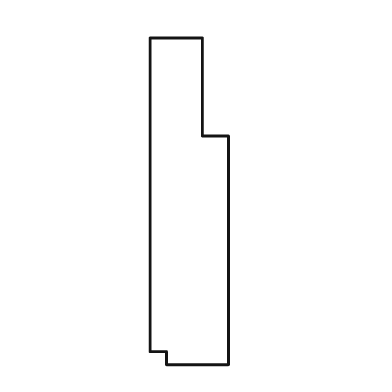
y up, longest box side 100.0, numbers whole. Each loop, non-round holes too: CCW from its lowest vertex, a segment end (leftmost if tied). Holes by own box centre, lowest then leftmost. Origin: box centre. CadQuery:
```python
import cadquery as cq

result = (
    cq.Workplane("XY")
    .moveTo(-7.0, -50.0)
    .lineTo(12.0, -50.0)
    .lineTo(12.0, 20.0)
    .lineTo(4.0, 20.0)
    .lineTo(4.0, 50.0)
    .lineTo(-12.0, 50.0)
    .lineTo(-12.0, -46.0)
    .lineTo(-7.0, -46.0)
    .close()
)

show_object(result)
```